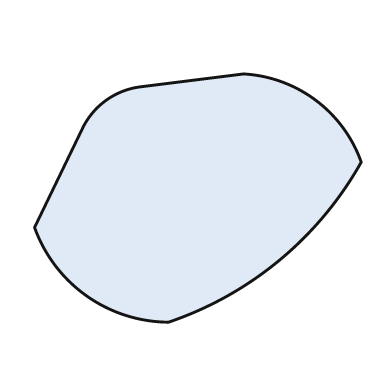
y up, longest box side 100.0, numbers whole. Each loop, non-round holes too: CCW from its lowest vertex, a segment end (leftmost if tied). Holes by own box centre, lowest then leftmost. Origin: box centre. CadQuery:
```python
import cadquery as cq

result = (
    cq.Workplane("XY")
    .moveTo(-9.0, -38.0)
    .threePointArc((25.0, -19.0), (50.0, 11.0))
    .threePointArc((36.0, 30.0), (14.0, 38.0))
    .lineTo(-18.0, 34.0)
    .threePointArc((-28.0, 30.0), (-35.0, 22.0))
    .lineTo(-50.0, -9.0)
    .threePointArc((-34.0, -30.0), (-9.0, -38.0))
    .close()
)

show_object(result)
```